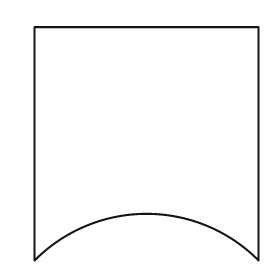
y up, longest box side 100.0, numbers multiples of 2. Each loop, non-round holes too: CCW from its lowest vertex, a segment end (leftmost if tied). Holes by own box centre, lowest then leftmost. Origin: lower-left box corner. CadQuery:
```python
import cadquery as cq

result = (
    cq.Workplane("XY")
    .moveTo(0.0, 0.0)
    .threePointArc((48.0, 20.0), (96.0, 0.0))
    .lineTo(96.0, 100.0)
    .lineTo(0.0, 100.0)
    .close()
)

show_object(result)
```